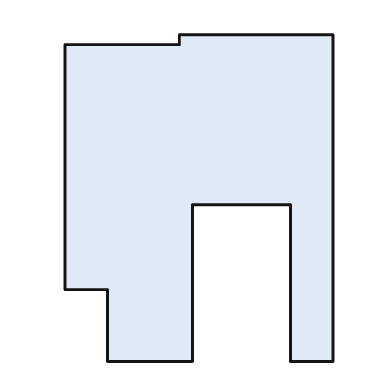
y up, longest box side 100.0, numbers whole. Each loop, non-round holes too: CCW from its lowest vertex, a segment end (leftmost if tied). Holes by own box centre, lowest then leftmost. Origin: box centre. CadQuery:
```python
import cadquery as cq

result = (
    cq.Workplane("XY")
    .moveTo(-28.0, -50.0)
    .lineTo(-2.0, -50.0)
    .lineTo(-2.0, -2.0)
    .lineTo(28.0, -2.0)
    .lineTo(28.0, -50.0)
    .lineTo(41.0, -50.0)
    .lineTo(41.0, 50.0)
    .lineTo(-6.0, 50.0)
    .lineTo(-6.0, 47.0)
    .lineTo(-41.0, 47.0)
    .lineTo(-41.0, -28.0)
    .lineTo(-28.0, -28.0)
    .close()
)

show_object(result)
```